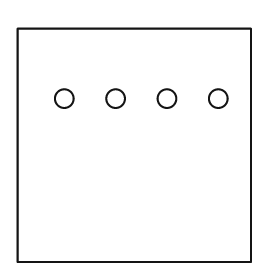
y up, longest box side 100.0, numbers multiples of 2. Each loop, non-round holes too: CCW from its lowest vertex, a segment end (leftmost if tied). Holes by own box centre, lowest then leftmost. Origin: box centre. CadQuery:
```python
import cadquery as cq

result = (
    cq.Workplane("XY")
    .moveTo(-50.0, -50.0)
    .lineTo(50.0, -50.0)
    .lineTo(50.0, 50.0)
    .lineTo(-50.0, 50.0)
    .close()
    .moveTo(-30.0, 20.0)
    .circle(4.0)
    .moveTo(-8.0, 20.0)
    .circle(4.0)
    .moveTo(14.0, 20.0)
    .circle(4.0)
    .moveTo(36.0, 20.0)
    .circle(4.0)
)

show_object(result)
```